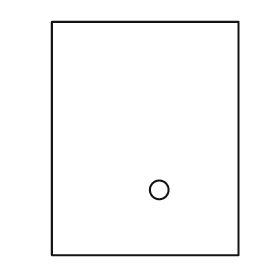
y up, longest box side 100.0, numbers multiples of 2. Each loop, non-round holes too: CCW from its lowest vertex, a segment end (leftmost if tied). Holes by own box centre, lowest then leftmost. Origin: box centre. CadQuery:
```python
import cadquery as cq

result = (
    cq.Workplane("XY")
    .moveTo(-40.0, -50.0)
    .lineTo(40.0, -50.0)
    .lineTo(40.0, 50.0)
    .lineTo(-40.0, 50.0)
    .close()
    .moveTo(6.0, -22.0)
    .circle(4.0)
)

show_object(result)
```